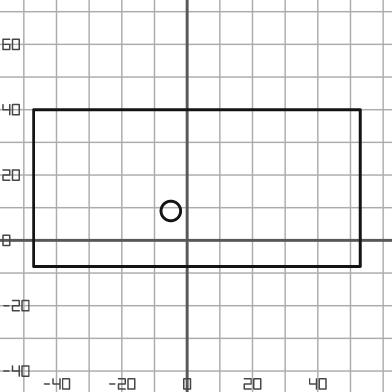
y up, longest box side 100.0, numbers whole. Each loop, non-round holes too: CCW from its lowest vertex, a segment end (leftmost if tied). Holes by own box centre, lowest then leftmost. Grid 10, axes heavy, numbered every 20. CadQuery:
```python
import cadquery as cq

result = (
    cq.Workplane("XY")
    .moveTo(-47.0, -8.0)
    .lineTo(53.0, -8.0)
    .lineTo(53.0, 40.0)
    .lineTo(-47.0, 40.0)
    .close()
    .moveTo(-5.0, 9.0)
    .circle(3.0)
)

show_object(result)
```